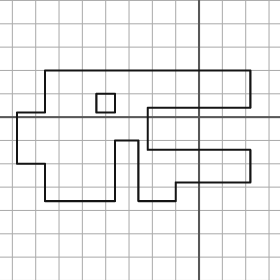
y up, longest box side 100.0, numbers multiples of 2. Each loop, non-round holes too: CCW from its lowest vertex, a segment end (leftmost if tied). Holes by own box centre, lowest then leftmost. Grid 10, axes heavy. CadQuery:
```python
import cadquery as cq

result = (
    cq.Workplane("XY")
    .moveTo(-66.0, -36.0)
    .lineTo(-36.0, -36.0)
    .lineTo(-36.0, -10.0)
    .lineTo(-26.0, -10.0)
    .lineTo(-26.0, -36.0)
    .lineTo(-10.0, -36.0)
    .lineTo(-10.0, -28.0)
    .lineTo(22.0, -28.0)
    .lineTo(22.0, -14.0)
    .lineTo(-22.0, -14.0)
    .lineTo(-22.0, 4.0)
    .lineTo(22.0, 4.0)
    .lineTo(22.0, 20.0)
    .lineTo(-66.0, 20.0)
    .lineTo(-66.0, 2.0)
    .lineTo(-78.0, 2.0)
    .lineTo(-78.0, -20.0)
    .lineTo(-66.0, -20.0)
    .close()
    .moveTo(-44.0, 2.0)
    .lineTo(-36.0, 2.0)
    .lineTo(-36.0, 10.0)
    .lineTo(-44.0, 10.0)
    .close()
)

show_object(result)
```